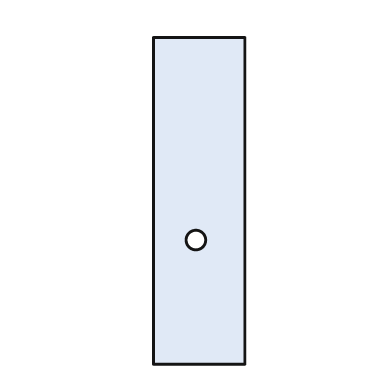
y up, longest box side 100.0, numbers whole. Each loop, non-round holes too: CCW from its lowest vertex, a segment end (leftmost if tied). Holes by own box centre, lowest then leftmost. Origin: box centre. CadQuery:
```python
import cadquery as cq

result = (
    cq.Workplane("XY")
    .moveTo(-14.0, -50.0)
    .lineTo(14.0, -50.0)
    .lineTo(14.0, 50.0)
    .lineTo(-14.0, 50.0)
    .close()
    .moveTo(-1.0, -12.0)
    .circle(3.0)
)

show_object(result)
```